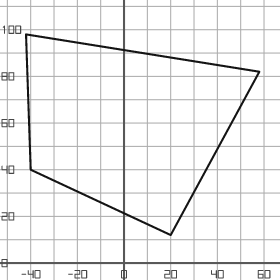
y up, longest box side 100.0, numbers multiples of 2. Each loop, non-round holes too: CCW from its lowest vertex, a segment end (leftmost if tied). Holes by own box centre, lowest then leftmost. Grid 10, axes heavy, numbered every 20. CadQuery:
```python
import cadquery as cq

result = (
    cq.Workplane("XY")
    .moveTo(20.0, 12.0)
    .lineTo(58.0, 82.0)
    .lineTo(-42.0, 98.0)
    .lineTo(-40.0, 40.0)
    .close()
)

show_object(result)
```